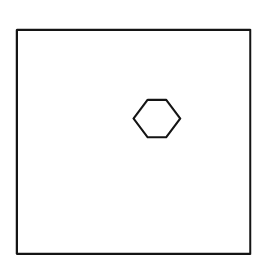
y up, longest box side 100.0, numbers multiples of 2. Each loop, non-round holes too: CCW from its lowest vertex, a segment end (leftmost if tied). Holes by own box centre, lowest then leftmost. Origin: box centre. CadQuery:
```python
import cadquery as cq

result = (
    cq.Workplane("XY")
    .moveTo(-50.0, -48.0)
    .lineTo(50.0, -48.0)
    .lineTo(50.0, 48.0)
    .lineTo(-50.0, 48.0)
    .close()
    .moveTo(6.0, 2.0)
    .lineTo(14.0, 2.0)
    .lineTo(20.0, 10.0)
    .lineTo(14.0, 18.0)
    .lineTo(6.0, 18.0)
    .lineTo(0.0, 10.0)
    .close()
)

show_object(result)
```